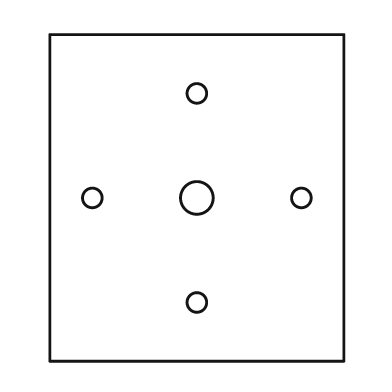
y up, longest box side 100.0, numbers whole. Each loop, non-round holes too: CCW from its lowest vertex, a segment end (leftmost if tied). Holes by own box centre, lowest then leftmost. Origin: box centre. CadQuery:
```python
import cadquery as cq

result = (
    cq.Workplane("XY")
    .moveTo(-45.0, -50.0)
    .lineTo(45.0, -50.0)
    .lineTo(45.0, 50.0)
    .lineTo(-45.0, 50.0)
    .close()
    .moveTo(0.0, -32.0)
    .circle(3.0)
    .moveTo(-32.0, 0.0)
    .circle(3.0)
    .moveTo(0.0, 0.0)
    .circle(5.0)
    .moveTo(32.0, 0.0)
    .circle(3.0)
    .moveTo(0.0, 32.0)
    .circle(3.0)
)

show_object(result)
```